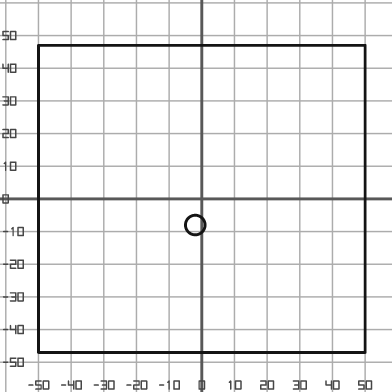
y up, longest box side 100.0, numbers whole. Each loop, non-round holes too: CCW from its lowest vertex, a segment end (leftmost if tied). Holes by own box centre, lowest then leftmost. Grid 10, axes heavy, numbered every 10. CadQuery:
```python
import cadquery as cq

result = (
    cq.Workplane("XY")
    .moveTo(-50.0, -47.0)
    .lineTo(50.0, -47.0)
    .lineTo(50.0, 47.0)
    .lineTo(-50.0, 47.0)
    .close()
    .moveTo(-2.0, -8.0)
    .circle(3.0)
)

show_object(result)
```